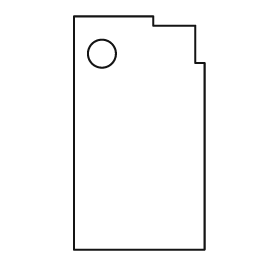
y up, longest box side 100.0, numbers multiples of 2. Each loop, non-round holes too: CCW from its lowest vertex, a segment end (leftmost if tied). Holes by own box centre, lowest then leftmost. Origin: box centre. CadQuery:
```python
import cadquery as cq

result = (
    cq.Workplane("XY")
    .moveTo(-28.0, -50.0)
    .lineTo(28.0, -50.0)
    .lineTo(28.0, 30.0)
    .lineTo(24.0, 30.0)
    .lineTo(24.0, 46.0)
    .lineTo(6.0, 46.0)
    .lineTo(6.0, 50.0)
    .lineTo(-28.0, 50.0)
    .close()
    .moveTo(-16.0, 34.0)
    .circle(6.0)
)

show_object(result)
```